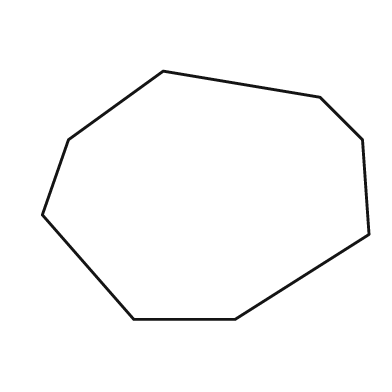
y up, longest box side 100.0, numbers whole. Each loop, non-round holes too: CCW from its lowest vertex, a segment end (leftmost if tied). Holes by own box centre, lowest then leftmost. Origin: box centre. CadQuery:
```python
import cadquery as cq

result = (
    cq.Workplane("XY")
    .moveTo(-22.0, -38.0)
    .lineTo(9.0, -38.0)
    .lineTo(50.0, -12.0)
    .lineTo(48.0, 17.0)
    .lineTo(35.0, 30.0)
    .lineTo(-13.0, 38.0)
    .lineTo(-42.0, 17.0)
    .lineTo(-50.0, -6.0)
    .close()
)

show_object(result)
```